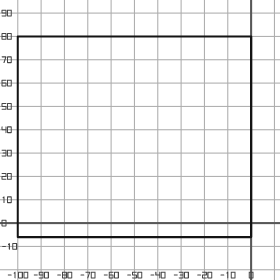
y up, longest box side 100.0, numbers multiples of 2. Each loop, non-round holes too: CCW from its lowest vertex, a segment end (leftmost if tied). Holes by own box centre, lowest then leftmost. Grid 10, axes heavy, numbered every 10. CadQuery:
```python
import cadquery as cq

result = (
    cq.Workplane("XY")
    .moveTo(-100.0, -6.0)
    .lineTo(0.0, -6.0)
    .lineTo(0.0, 80.0)
    .lineTo(-100.0, 80.0)
    .close()
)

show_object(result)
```